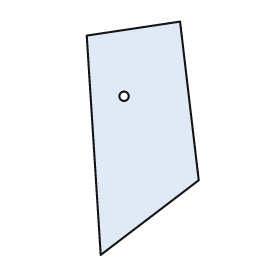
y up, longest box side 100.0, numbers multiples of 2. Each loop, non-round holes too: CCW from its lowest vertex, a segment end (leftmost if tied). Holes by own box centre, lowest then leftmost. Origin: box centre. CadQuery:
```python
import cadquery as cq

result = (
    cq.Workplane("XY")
    .moveTo(-18.0, -50.0)
    .lineTo(24.0, -18.0)
    .lineTo(16.0, 50.0)
    .lineTo(-24.0, 44.0)
    .close()
    .moveTo(-8.0, 18.0)
    .circle(2.0)
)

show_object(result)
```